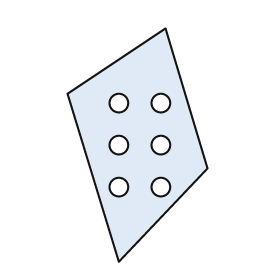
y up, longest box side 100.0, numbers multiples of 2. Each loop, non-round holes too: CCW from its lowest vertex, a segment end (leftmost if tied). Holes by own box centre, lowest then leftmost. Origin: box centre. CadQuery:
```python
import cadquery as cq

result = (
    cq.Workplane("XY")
    .moveTo(-8.0, -50.0)
    .lineTo(30.0, -10.0)
    .lineTo(12.0, 50.0)
    .lineTo(-30.0, 22.0)
    .close()
    .moveTo(-8.0, -18.0)
    .circle(4.0)
    .moveTo(10.0, -18.0)
    .circle(4.0)
    .moveTo(-8.0, 0.0)
    .circle(4.0)
    .moveTo(10.0, 0.0)
    .circle(4.0)
    .moveTo(-8.0, 18.0)
    .circle(4.0)
    .moveTo(10.0, 18.0)
    .circle(4.0)
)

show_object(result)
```